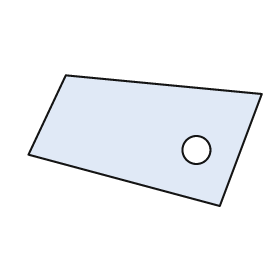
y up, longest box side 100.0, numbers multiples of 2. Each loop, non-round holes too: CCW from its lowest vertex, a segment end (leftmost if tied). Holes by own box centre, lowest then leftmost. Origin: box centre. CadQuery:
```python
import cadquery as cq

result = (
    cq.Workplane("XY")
    .moveTo(32.0, -28.0)
    .lineTo(50.0, 20.0)
    .lineTo(-34.0, 28.0)
    .lineTo(-50.0, -6.0)
    .close()
    .moveTo(22.0, -4.0)
    .circle(6.0)
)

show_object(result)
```